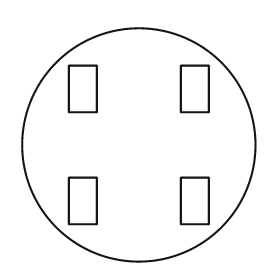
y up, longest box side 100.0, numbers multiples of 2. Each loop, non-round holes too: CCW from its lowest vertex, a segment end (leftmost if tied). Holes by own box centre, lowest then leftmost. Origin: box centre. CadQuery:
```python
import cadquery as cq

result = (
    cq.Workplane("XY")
    .moveTo(0.0, 0.0)
    .circle(50.0)
    .moveTo(-30.0, -34.0)
    .lineTo(-18.0, -34.0)
    .lineTo(-18.0, -14.0)
    .lineTo(-30.0, -14.0)
    .close()
    .moveTo(18.0, -34.0)
    .lineTo(30.0, -34.0)
    .lineTo(30.0, -14.0)
    .lineTo(18.0, -14.0)
    .close()
    .moveTo(-30.0, 14.0)
    .lineTo(-18.0, 14.0)
    .lineTo(-18.0, 34.0)
    .lineTo(-30.0, 34.0)
    .close()
    .moveTo(18.0, 14.0)
    .lineTo(30.0, 14.0)
    .lineTo(30.0, 34.0)
    .lineTo(18.0, 34.0)
    .close()
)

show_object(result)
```